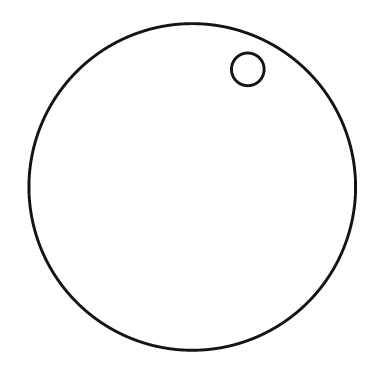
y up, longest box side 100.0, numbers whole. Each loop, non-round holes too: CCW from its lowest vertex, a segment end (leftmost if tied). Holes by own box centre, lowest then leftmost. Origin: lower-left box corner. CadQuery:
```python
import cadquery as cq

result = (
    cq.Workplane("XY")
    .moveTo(50.0, 50.0)
    .circle(50.0)
    .moveTo(67.0, 86.0)
    .circle(5.0)
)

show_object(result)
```